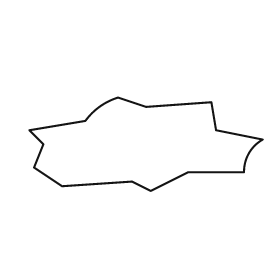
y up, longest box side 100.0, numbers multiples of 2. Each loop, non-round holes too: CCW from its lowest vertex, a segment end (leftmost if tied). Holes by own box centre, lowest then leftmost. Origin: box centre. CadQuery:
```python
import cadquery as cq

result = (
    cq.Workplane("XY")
    .moveTo(2.0, -20.0)
    .lineTo(18.0, -12.0)
    .lineTo(42.0, -12.0)
    .threePointArc((44.0, -4.0), (50.0, 2.0))
    .lineTo(30.0, 6.0)
    .lineTo(28.0, 18.0)
    .lineTo(0.0, 16.0)
    .lineTo(-12.0, 20.0)
    .threePointArc((-20.0, 16.0), (-26.0, 10.0))
    .lineTo(-50.0, 6.0)
    .lineTo(-44.0, 0.0)
    .lineTo(-48.0, -10.0)
    .lineTo(-36.0, -18.0)
    .lineTo(-6.0, -16.0)
    .close()
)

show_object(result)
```